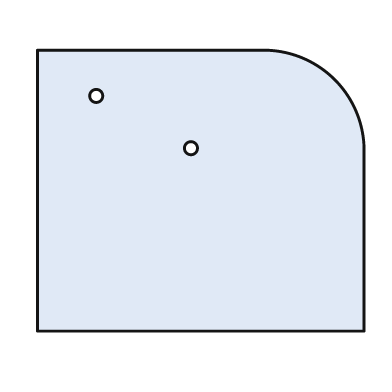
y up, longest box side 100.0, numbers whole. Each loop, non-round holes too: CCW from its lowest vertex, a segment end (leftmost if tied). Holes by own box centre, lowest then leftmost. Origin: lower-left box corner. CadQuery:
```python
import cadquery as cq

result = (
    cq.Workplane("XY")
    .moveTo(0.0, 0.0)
    .lineTo(100.0, 0.0)
    .lineTo(100.0, 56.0)
    .threePointArc((91.0, 77.0), (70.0, 86.0))
    .lineTo(0.0, 86.0)
    .close()
    .moveTo(47.0, 56.0)
    .circle(2.0)
    .moveTo(18.0, 72.0)
    .circle(2.0)
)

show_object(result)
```